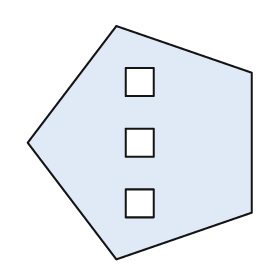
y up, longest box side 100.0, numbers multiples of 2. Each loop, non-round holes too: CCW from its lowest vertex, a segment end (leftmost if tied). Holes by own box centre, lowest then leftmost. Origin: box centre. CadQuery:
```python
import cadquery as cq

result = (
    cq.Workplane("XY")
    .moveTo(-10.0, -50.0)
    .lineTo(48.0, -30.0)
    .lineTo(48.0, 30.0)
    .lineTo(-10.0, 50.0)
    .lineTo(-48.0, 0.0)
    .close()
    .moveTo(-6.0, -32.0)
    .lineTo(6.0, -32.0)
    .lineTo(6.0, -20.0)
    .lineTo(-6.0, -20.0)
    .close()
    .moveTo(-6.0, -6.0)
    .lineTo(6.0, -6.0)
    .lineTo(6.0, 6.0)
    .lineTo(-6.0, 6.0)
    .close()
    .moveTo(-6.0, 20.0)
    .lineTo(6.0, 20.0)
    .lineTo(6.0, 32.0)
    .lineTo(-6.0, 32.0)
    .close()
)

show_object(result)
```